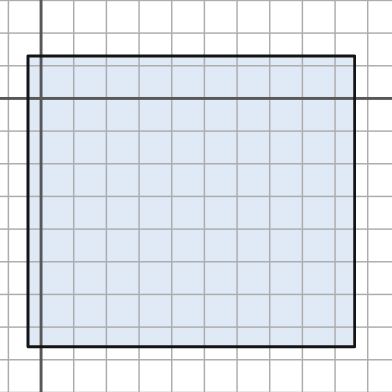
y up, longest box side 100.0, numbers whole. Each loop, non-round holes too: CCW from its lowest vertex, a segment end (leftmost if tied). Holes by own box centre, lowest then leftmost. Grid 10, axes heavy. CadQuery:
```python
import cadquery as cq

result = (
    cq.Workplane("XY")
    .moveTo(-4.0, -76.0)
    .lineTo(96.0, -76.0)
    .lineTo(96.0, 13.0)
    .lineTo(-4.0, 13.0)
    .close()
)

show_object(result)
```